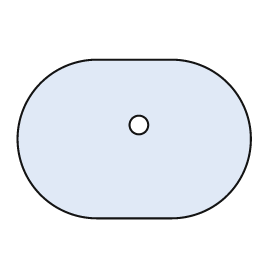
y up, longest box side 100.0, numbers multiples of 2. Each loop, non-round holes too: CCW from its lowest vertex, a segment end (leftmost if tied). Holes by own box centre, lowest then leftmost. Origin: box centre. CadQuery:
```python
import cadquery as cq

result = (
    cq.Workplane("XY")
    .moveTo(-16.0, -34.0)
    .lineTo(16.0, -34.0)
    .threePointArc((50.0, 0.0), (16.0, 34.0))
    .lineTo(-16.0, 34.0)
    .threePointArc((-50.0, 0.0), (-16.0, -34.0))
    .close()
    .moveTo(2.0, 6.0)
    .circle(4.0)
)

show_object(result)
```